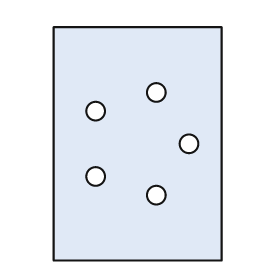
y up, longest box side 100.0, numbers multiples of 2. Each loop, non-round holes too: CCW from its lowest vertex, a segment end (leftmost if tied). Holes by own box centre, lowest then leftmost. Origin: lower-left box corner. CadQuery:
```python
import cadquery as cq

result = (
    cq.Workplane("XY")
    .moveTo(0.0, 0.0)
    .lineTo(72.0, 0.0)
    .lineTo(72.0, 100.0)
    .lineTo(0.0, 100.0)
    .close()
    .moveTo(44.0, 28.0)
    .circle(4.0)
    .moveTo(18.0, 36.0)
    .circle(4.0)
    .moveTo(58.0, 50.0)
    .circle(4.0)
    .moveTo(18.0, 64.0)
    .circle(4.0)
    .moveTo(44.0, 72.0)
    .circle(4.0)
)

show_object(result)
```